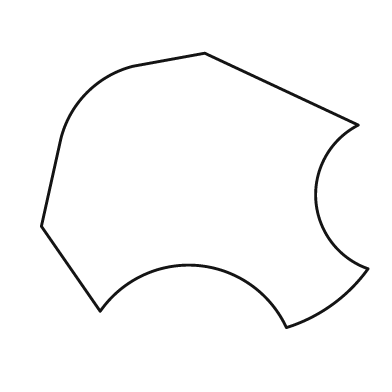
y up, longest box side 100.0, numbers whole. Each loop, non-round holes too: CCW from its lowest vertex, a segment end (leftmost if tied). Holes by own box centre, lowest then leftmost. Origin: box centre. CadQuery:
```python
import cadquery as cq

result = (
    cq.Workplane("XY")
    .moveTo(25.0, -42.0)
    .threePointArc((39.0, -35.0), (50.0, -24.0))
    .threePointArc((34.0, -3.0), (47.0, 20.0))
    .lineTo(0.0, 42.0)
    .lineTo(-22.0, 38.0)
    .threePointArc((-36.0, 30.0), (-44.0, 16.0))
    .lineTo(-50.0, -11.0)
    .lineTo(-32.0, -37.0)
    .threePointArc((-2.0, -23.0), (25.0, -42.0))
    .close()
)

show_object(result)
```